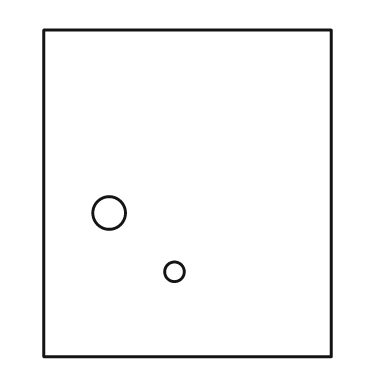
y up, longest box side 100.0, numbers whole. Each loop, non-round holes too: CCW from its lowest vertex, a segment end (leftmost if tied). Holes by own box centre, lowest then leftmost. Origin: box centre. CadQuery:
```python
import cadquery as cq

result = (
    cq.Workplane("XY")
    .moveTo(-44.0, -50.0)
    .lineTo(44.0, -50.0)
    .lineTo(44.0, 50.0)
    .lineTo(-44.0, 50.0)
    .close()
    .moveTo(-4.0, -24.0)
    .circle(3.0)
    .moveTo(-24.0, -6.0)
    .circle(5.0)
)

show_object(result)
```